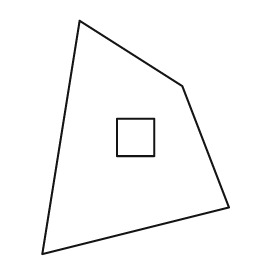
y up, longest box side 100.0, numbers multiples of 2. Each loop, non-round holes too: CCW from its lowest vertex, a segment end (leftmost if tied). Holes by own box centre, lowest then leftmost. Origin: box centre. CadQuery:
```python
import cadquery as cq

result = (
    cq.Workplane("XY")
    .moveTo(-40.0, -50.0)
    .lineTo(40.0, -30.0)
    .lineTo(20.0, 22.0)
    .lineTo(-24.0, 50.0)
    .close()
    .moveTo(-8.0, -8.0)
    .lineTo(8.0, -8.0)
    .lineTo(8.0, 8.0)
    .lineTo(-8.0, 8.0)
    .close()
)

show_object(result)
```